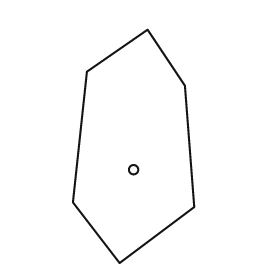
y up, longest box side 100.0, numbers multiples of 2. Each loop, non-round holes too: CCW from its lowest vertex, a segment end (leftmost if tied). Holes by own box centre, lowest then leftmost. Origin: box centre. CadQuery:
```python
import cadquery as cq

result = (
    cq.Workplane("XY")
    .moveTo(-6.0, -50.0)
    .lineTo(26.0, -26.0)
    .lineTo(22.0, 26.0)
    .lineTo(6.0, 50.0)
    .lineTo(-20.0, 32.0)
    .lineTo(-26.0, -24.0)
    .close()
    .moveTo(0.0, -10.0)
    .circle(2.0)
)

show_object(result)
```